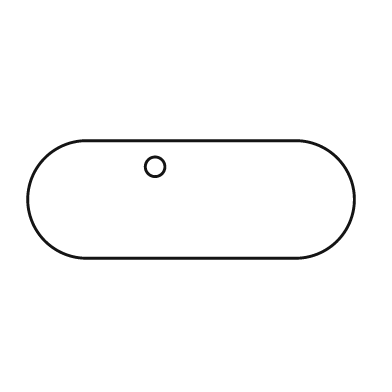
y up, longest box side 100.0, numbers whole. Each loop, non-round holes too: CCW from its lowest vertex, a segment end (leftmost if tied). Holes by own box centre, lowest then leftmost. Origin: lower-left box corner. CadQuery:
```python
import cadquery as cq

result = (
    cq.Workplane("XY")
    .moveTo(18.0, 0.0)
    .lineTo(82.0, 0.0)
    .threePointArc((100.0, 18.0), (82.0, 36.0))
    .lineTo(18.0, 36.0)
    .threePointArc((0.0, 18.0), (18.0, 0.0))
    .close()
    .moveTo(39.0, 28.0)
    .circle(3.0)
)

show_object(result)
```